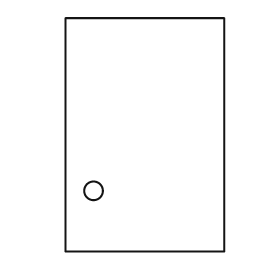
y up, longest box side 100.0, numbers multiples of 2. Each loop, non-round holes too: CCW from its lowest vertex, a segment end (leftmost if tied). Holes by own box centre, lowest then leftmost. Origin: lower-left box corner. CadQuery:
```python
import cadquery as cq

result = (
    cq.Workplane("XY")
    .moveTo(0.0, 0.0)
    .lineTo(68.0, 0.0)
    .lineTo(68.0, 100.0)
    .lineTo(0.0, 100.0)
    .close()
    .moveTo(12.0, 26.0)
    .circle(4.0)
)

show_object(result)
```